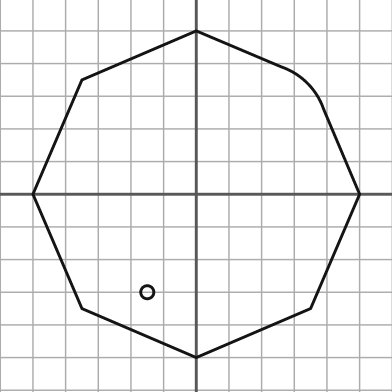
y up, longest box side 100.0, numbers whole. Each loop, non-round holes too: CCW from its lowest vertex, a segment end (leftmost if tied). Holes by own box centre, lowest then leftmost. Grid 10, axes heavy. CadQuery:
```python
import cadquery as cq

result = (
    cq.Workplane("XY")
    .moveTo(0.0, -50.0)
    .lineTo(35.0, -35.0)
    .lineTo(50.0, 0.0)
    .lineTo(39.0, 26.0)
    .threePointArc((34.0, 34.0), (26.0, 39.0))
    .lineTo(0.0, 50.0)
    .lineTo(-35.0, 35.0)
    .lineTo(-50.0, 0.0)
    .lineTo(-35.0, -35.0)
    .close()
    .moveTo(-15.0, -30.0)
    .circle(2.0)
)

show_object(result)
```